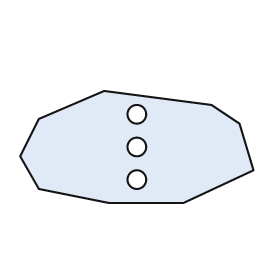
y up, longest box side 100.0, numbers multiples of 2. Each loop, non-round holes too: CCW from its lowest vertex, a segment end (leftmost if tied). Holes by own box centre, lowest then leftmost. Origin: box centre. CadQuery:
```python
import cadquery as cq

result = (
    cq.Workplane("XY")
    .moveTo(-12.0, -24.0)
    .lineTo(20.0, -24.0)
    .lineTo(50.0, -10.0)
    .lineTo(44.0, 10.0)
    .lineTo(32.0, 18.0)
    .lineTo(-14.0, 24.0)
    .lineTo(-42.0, 12.0)
    .lineTo(-50.0, -4.0)
    .lineTo(-42.0, -18.0)
    .close()
    .moveTo(0.0, -14.0)
    .circle(4.0)
    .moveTo(0.0, 0.0)
    .circle(4.0)
    .moveTo(0.0, 14.0)
    .circle(4.0)
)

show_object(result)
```